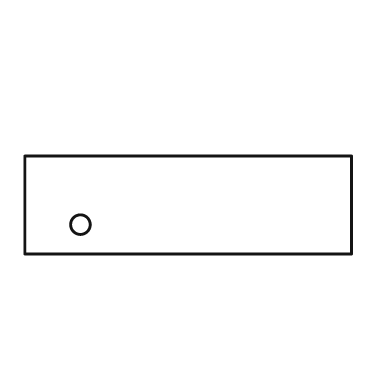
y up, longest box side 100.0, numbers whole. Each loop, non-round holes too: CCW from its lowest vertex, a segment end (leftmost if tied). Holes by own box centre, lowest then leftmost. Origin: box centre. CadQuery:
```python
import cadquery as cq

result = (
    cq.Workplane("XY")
    .moveTo(-50.0, -15.0)
    .lineTo(50.0, -15.0)
    .lineTo(50.0, 15.0)
    .lineTo(-50.0, 15.0)
    .close()
    .moveTo(-33.0, -6.0)
    .circle(3.0)
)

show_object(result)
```